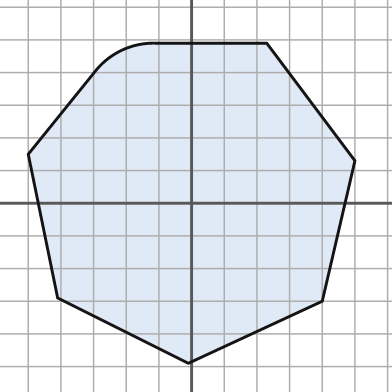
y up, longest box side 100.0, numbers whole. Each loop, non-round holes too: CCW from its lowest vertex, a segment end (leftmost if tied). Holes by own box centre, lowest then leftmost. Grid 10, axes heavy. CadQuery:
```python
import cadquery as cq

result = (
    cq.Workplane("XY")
    .moveTo(-1.0, -49.0)
    .lineTo(40.0, -30.0)
    .lineTo(50.0, 13.0)
    .lineTo(23.0, 49.0)
    .lineTo(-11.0, 49.0)
    .threePointArc((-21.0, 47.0), (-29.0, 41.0))
    .lineTo(-50.0, 15.0)
    .lineTo(-41.0, -29.0)
    .close()
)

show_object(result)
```